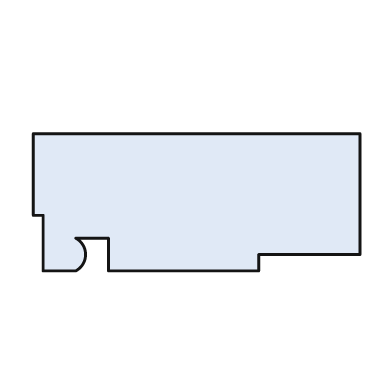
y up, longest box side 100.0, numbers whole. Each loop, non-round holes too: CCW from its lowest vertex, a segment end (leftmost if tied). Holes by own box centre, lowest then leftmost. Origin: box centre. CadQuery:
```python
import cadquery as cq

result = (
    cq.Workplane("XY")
    .moveTo(-47.0, -21.0)
    .lineTo(-37.0, -21.0)
    .threePointArc((-34.0, -16.0), (-37.0, -11.0))
    .lineTo(-27.0, -11.0)
    .lineTo(-27.0, -21.0)
    .lineTo(19.0, -21.0)
    .lineTo(19.0, -16.0)
    .lineTo(50.0, -16.0)
    .lineTo(50.0, 21.0)
    .lineTo(-50.0, 21.0)
    .lineTo(-50.0, -4.0)
    .lineTo(-47.0, -4.0)
    .close()
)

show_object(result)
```